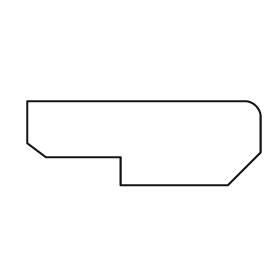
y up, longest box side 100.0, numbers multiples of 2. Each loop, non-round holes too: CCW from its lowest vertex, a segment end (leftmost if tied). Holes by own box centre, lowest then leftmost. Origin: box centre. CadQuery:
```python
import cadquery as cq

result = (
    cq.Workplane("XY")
    .moveTo(-10.0, -18.0)
    .lineTo(36.0, -18.0)
    .lineTo(50.0, -4.0)
    .lineTo(50.0, 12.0)
    .threePointArc((48.0, 16.0), (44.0, 18.0))
    .lineTo(-50.0, 18.0)
    .lineTo(-50.0, 0.0)
    .lineTo(-42.0, -6.0)
    .lineTo(-10.0, -6.0)
    .close()
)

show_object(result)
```